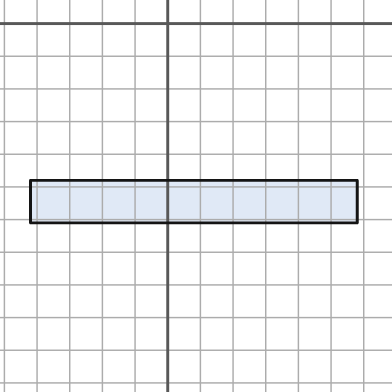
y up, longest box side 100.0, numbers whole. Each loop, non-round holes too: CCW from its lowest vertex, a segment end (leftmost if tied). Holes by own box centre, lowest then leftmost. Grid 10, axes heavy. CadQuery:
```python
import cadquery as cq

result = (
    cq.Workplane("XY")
    .moveTo(-42.0, -61.0)
    .lineTo(58.0, -61.0)
    .lineTo(58.0, -48.0)
    .lineTo(-42.0, -48.0)
    .close()
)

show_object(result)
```